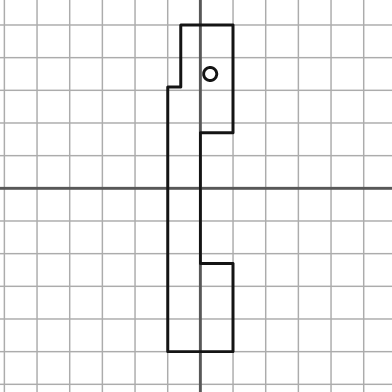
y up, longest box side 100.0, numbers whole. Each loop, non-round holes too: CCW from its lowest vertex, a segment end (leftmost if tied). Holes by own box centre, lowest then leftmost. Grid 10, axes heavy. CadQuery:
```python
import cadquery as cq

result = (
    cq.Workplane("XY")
    .moveTo(-10.0, -50.0)
    .lineTo(10.0, -50.0)
    .lineTo(10.0, -23.0)
    .lineTo(0.0, -23.0)
    .lineTo(0.0, 17.0)
    .lineTo(10.0, 17.0)
    .lineTo(10.0, 50.0)
    .lineTo(-6.0, 50.0)
    .lineTo(-6.0, 31.0)
    .lineTo(-10.0, 31.0)
    .close()
    .moveTo(3.0, 35.0)
    .circle(2.0)
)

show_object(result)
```